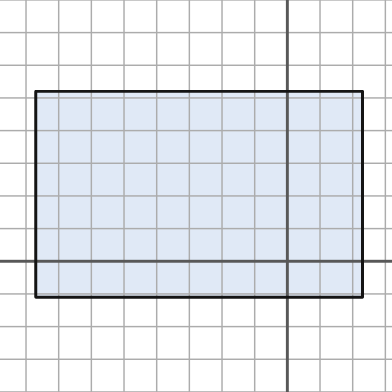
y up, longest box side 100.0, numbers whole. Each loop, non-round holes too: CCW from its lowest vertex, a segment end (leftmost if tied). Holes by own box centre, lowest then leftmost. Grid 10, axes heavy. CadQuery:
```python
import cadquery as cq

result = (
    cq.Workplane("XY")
    .moveTo(-77.0, -11.0)
    .lineTo(23.0, -11.0)
    .lineTo(23.0, 52.0)
    .lineTo(-77.0, 52.0)
    .close()
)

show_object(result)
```